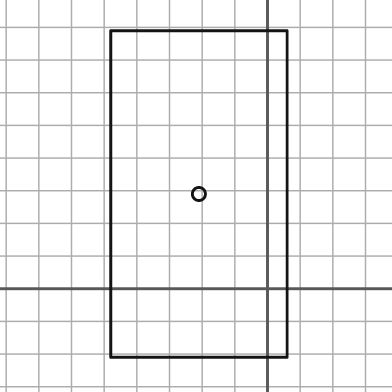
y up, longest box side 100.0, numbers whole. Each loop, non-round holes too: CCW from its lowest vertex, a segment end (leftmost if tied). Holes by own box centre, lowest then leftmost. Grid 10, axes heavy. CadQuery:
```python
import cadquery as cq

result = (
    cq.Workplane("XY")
    .moveTo(-48.0, -21.0)
    .lineTo(6.0, -21.0)
    .lineTo(6.0, 79.0)
    .lineTo(-48.0, 79.0)
    .close()
    .moveTo(-21.0, 29.0)
    .circle(2.0)
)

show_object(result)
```